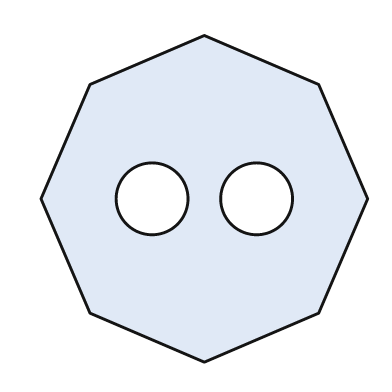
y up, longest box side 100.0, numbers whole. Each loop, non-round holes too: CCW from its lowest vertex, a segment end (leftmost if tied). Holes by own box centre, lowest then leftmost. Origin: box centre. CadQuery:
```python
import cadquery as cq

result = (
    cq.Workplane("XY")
    .moveTo(0.0, -50.0)
    .lineTo(35.0, -35.0)
    .lineTo(50.0, 0.0)
    .lineTo(35.0, 35.0)
    .lineTo(0.0, 50.0)
    .lineTo(-35.0, 35.0)
    .lineTo(-50.0, 0.0)
    .lineTo(-35.0, -35.0)
    .close()
    .moveTo(-16.0, 0.0)
    .circle(11.0)
    .moveTo(16.0, 0.0)
    .circle(11.0)
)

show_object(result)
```